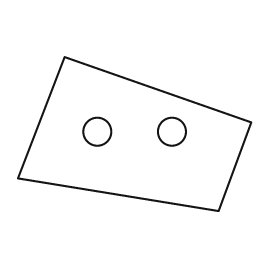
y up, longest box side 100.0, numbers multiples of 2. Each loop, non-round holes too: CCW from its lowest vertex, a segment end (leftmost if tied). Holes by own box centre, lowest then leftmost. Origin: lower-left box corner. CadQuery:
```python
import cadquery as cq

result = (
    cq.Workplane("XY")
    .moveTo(86.0, 0.0)
    .lineTo(100.0, 38.0)
    .lineTo(20.0, 66.0)
    .lineTo(0.0, 14.0)
    .close()
    .moveTo(34.0, 34.0)
    .circle(6.0)
    .moveTo(66.0, 34.0)
    .circle(6.0)
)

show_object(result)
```